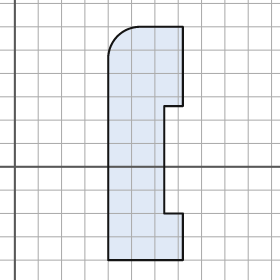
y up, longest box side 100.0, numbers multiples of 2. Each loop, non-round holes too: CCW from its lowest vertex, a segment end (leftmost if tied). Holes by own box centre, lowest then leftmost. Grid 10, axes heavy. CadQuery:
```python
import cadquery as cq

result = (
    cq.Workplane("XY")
    .moveTo(40.0, -40.0)
    .lineTo(72.0, -40.0)
    .lineTo(72.0, -20.0)
    .lineTo(64.0, -20.0)
    .lineTo(64.0, 26.0)
    .lineTo(72.0, 26.0)
    .lineTo(72.0, 60.0)
    .lineTo(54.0, 60.0)
    .threePointArc((44.0, 56.0), (40.0, 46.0))
    .close()
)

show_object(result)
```